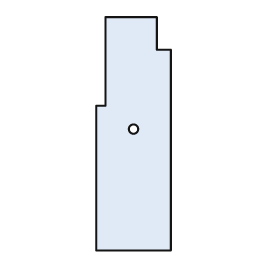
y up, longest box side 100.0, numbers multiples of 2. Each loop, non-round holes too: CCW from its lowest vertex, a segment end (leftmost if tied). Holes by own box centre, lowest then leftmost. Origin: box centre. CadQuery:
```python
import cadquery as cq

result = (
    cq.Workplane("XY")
    .moveTo(-16.0, -50.0)
    .lineTo(16.0, -50.0)
    .lineTo(16.0, 36.0)
    .lineTo(10.0, 36.0)
    .lineTo(10.0, 50.0)
    .lineTo(-12.0, 50.0)
    .lineTo(-12.0, 12.0)
    .lineTo(-16.0, 12.0)
    .close()
    .moveTo(0.0, 2.0)
    .circle(2.0)
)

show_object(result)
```